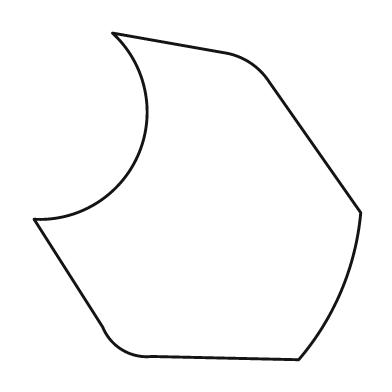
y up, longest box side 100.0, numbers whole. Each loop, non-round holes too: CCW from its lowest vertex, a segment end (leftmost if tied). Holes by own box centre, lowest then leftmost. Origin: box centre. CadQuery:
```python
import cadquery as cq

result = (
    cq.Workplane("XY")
    .moveTo(31.0, -50.0)
    .threePointArc((44.0, -29.0), (50.0, -5.0))
    .lineTo(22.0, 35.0)
    .threePointArc((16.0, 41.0), (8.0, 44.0))
    .lineTo(-26.0, 50.0)
    .threePointArc((-18.0, 13.0), (-50.0, -7.0))
    .lineTo(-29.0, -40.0)
    .threePointArc((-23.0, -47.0), (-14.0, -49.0))
    .close()
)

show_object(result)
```